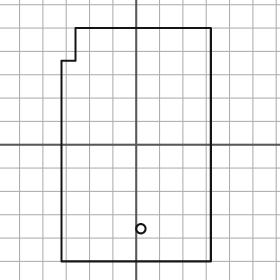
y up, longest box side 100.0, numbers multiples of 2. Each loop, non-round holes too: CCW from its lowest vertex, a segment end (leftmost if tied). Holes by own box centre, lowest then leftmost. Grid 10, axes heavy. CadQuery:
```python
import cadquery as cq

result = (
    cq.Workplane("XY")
    .moveTo(-32.0, -50.0)
    .lineTo(32.0, -50.0)
    .lineTo(32.0, 50.0)
    .lineTo(-26.0, 50.0)
    .lineTo(-26.0, 36.0)
    .lineTo(-32.0, 36.0)
    .close()
    .moveTo(2.0, -36.0)
    .circle(2.0)
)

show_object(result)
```